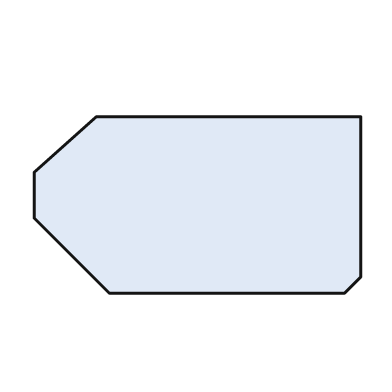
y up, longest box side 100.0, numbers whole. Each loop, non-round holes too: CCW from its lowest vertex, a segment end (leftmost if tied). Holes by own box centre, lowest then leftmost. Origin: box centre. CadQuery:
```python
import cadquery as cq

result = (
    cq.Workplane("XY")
    .moveTo(-27.0, -27.0)
    .lineTo(45.0, -27.0)
    .lineTo(50.0, -22.0)
    .lineTo(50.0, 27.0)
    .lineTo(-31.0, 27.0)
    .lineTo(-50.0, 10.0)
    .lineTo(-50.0, -4.0)
    .close()
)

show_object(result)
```